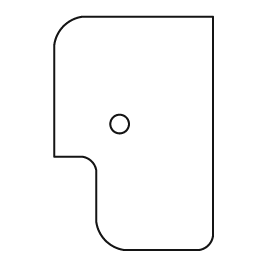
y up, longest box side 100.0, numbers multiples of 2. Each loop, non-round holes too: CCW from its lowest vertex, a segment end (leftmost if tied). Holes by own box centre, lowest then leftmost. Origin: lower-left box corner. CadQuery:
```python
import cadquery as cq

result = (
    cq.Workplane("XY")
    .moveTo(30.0, 0.0)
    .lineTo(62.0, 0.0)
    .threePointArc((66.0, 2.0), (68.0, 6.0))
    .lineTo(68.0, 100.0)
    .lineTo(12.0, 100.0)
    .threePointArc((4.0, 96.0), (0.0, 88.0))
    .lineTo(0.0, 40.0)
    .lineTo(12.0, 40.0)
    .threePointArc((16.0, 38.0), (18.0, 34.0))
    .lineTo(18.0, 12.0)
    .threePointArc((22.0, 4.0), (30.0, 0.0))
    .close()
    .moveTo(28.0, 54.0)
    .circle(4.0)
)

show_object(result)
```